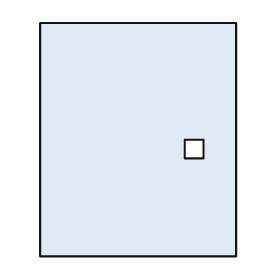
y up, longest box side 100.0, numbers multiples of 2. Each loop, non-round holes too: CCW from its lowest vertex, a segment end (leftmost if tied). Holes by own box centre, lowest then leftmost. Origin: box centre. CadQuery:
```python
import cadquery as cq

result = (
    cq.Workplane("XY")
    .moveTo(-42.0, -50.0)
    .lineTo(42.0, -50.0)
    .lineTo(42.0, 50.0)
    .lineTo(-42.0, 50.0)
    .close()
    .moveTo(20.0, -8.0)
    .lineTo(28.0, -8.0)
    .lineTo(28.0, 0.0)
    .lineTo(20.0, 0.0)
    .close()
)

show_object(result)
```